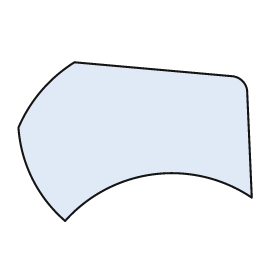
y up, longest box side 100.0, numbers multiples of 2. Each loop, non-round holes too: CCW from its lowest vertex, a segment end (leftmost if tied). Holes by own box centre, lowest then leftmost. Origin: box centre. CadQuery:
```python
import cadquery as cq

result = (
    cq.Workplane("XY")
    .moveTo(-30.0, -34.0)
    .threePointArc((8.0, -14.0), (50.0, -24.0))
    .lineTo(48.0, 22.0)
    .threePointArc((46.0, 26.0), (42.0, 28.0))
    .lineTo(-26.0, 34.0)
    .threePointArc((-40.0, 22.0), (-50.0, 6.0))
    .threePointArc((-44.0, -16.0), (-30.0, -34.0))
    .close()
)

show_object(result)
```